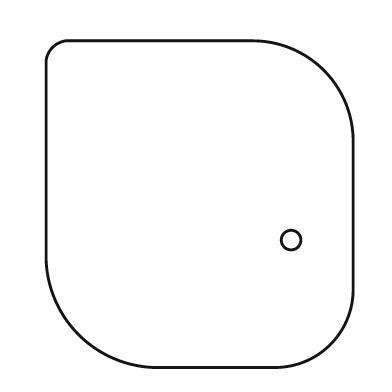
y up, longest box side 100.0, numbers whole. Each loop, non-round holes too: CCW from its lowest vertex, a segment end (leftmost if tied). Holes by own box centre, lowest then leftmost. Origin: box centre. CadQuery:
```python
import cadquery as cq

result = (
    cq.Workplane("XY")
    .moveTo(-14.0, -50.0)
    .lineTo(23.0, -50.0)
    .threePointArc((40.0, -43.0), (47.0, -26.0))
    .lineTo(47.0, 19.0)
    .threePointArc((38.0, 41.0), (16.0, 50.0))
    .lineTo(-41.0, 50.0)
    .threePointArc((-45.0, 48.0), (-47.0, 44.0))
    .lineTo(-47.0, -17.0)
    .threePointArc((-37.0, -40.0), (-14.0, -50.0))
    .close()
    .moveTo(28.0, -11.0)
    .circle(3.0)
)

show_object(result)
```